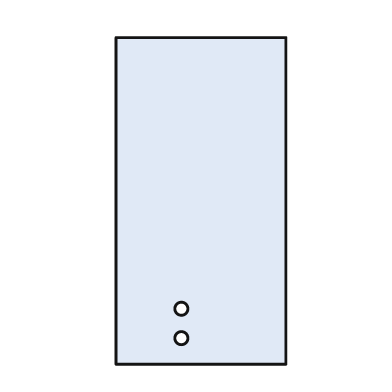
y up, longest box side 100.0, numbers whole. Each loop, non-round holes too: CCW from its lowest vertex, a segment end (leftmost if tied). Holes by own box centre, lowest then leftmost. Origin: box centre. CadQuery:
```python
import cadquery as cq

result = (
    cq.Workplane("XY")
    .moveTo(-26.0, -50.0)
    .lineTo(26.0, -50.0)
    .lineTo(26.0, 50.0)
    .lineTo(-26.0, 50.0)
    .close()
    .moveTo(-6.0, -42.0)
    .circle(2.0)
    .moveTo(-6.0, -33.0)
    .circle(2.0)
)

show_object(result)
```